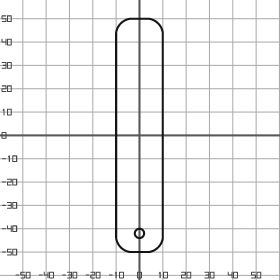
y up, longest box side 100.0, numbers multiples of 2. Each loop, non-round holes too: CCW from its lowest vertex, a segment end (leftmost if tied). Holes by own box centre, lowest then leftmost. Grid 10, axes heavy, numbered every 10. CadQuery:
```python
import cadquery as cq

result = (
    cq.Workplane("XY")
    .moveTo(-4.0, -50.0)
    .lineTo(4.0, -50.0)
    .threePointArc((8.0, -48.0), (10.0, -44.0))
    .lineTo(10.0, 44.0)
    .threePointArc((8.0, 48.0), (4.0, 50.0))
    .lineTo(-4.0, 50.0)
    .threePointArc((-8.0, 48.0), (-10.0, 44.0))
    .lineTo(-10.0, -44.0)
    .threePointArc((-8.0, -48.0), (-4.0, -50.0))
    .close()
    .moveTo(0.0, -42.0)
    .circle(2.0)
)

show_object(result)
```